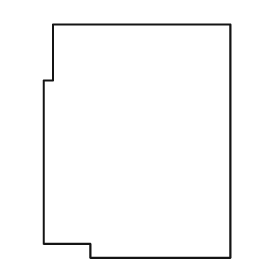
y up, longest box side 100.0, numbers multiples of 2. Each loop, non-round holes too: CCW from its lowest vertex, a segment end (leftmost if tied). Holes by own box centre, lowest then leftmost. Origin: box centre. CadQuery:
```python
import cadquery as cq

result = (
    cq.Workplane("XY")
    .moveTo(-20.0, -50.0)
    .lineTo(40.0, -50.0)
    .lineTo(40.0, 50.0)
    .lineTo(-36.0, 50.0)
    .lineTo(-36.0, 26.0)
    .lineTo(-40.0, 26.0)
    .lineTo(-40.0, -44.0)
    .lineTo(-20.0, -44.0)
    .close()
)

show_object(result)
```